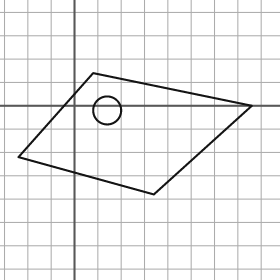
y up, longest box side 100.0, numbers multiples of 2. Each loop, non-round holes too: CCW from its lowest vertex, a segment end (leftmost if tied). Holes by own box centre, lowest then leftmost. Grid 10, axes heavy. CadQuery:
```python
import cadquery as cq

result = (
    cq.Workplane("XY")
    .moveTo(34.0, -38.0)
    .lineTo(76.0, 0.0)
    .lineTo(8.0, 14.0)
    .lineTo(-24.0, -22.0)
    .close()
    .moveTo(14.0, -2.0)
    .circle(6.0)
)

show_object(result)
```